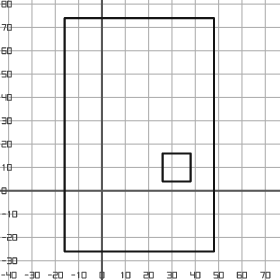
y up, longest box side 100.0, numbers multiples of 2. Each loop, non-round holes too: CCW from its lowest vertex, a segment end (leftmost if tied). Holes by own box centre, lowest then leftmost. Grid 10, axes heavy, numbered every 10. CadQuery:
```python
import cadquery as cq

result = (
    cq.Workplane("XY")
    .moveTo(-16.0, -26.0)
    .lineTo(48.0, -26.0)
    .lineTo(48.0, 74.0)
    .lineTo(-16.0, 74.0)
    .close()
    .moveTo(26.0, 4.0)
    .lineTo(38.0, 4.0)
    .lineTo(38.0, 16.0)
    .lineTo(26.0, 16.0)
    .close()
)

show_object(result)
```